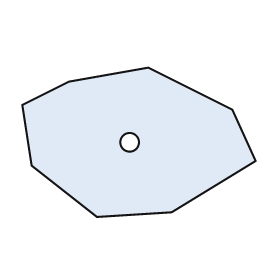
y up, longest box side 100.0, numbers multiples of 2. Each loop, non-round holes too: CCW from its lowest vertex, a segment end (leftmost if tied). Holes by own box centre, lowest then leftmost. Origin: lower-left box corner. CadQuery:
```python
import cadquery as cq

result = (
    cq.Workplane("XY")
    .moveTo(32.0, 0.0)
    .lineTo(64.0, 2.0)
    .lineTo(100.0, 24.0)
    .lineTo(90.0, 46.0)
    .lineTo(54.0, 64.0)
    .lineTo(20.0, 58.0)
    .lineTo(0.0, 48.0)
    .lineTo(4.0, 22.0)
    .close()
    .moveTo(46.0, 32.0)
    .circle(4.0)
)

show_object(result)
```